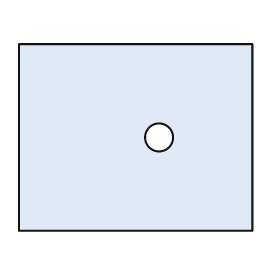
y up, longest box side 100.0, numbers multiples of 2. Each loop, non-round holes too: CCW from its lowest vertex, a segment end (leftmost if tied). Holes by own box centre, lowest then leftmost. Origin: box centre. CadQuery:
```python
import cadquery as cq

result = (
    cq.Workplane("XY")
    .moveTo(-50.0, -40.0)
    .lineTo(50.0, -40.0)
    .lineTo(50.0, 40.0)
    .lineTo(-50.0, 40.0)
    .close()
    .moveTo(10.0, 0.0)
    .circle(6.0)
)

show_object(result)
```